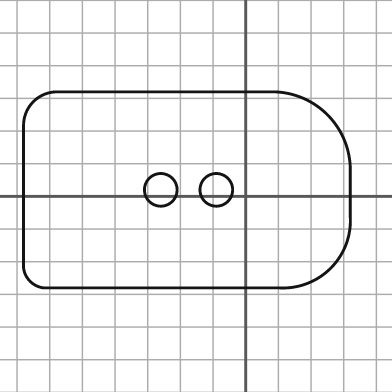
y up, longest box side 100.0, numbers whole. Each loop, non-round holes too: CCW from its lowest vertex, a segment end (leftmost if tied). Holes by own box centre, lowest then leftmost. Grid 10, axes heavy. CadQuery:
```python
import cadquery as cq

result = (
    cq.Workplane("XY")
    .moveTo(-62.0, -28.0)
    .lineTo(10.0, -28.0)
    .threePointArc((26.0, -22.0), (32.0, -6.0))
    .lineTo(32.0, 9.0)
    .threePointArc((25.0, 25.0), (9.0, 32.0))
    .lineTo(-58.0, 32.0)
    .threePointArc((-65.0, 29.0), (-68.0, 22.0))
    .lineTo(-68.0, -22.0)
    .threePointArc((-66.0, -26.0), (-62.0, -28.0))
    .close()
    .moveTo(-26.0, 2.0)
    .circle(5.0)
    .moveTo(-9.0, 2.0)
    .circle(5.0)
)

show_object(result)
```